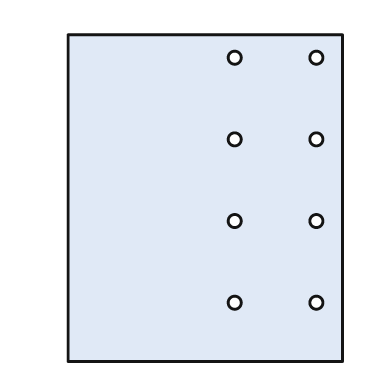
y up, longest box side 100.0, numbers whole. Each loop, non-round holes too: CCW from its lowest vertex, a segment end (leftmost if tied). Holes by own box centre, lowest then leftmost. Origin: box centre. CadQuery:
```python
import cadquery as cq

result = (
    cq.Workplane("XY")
    .moveTo(-42.0, -50.0)
    .lineTo(42.0, -50.0)
    .lineTo(42.0, 50.0)
    .lineTo(-42.0, 50.0)
    .close()
    .moveTo(9.0, -32.0)
    .circle(2.0)
    .moveTo(34.0, -32.0)
    .circle(2.0)
    .moveTo(9.0, -7.0)
    .circle(2.0)
    .moveTo(34.0, -7.0)
    .circle(2.0)
    .moveTo(9.0, 18.0)
    .circle(2.0)
    .moveTo(34.0, 18.0)
    .circle(2.0)
    .moveTo(9.0, 43.0)
    .circle(2.0)
    .moveTo(34.0, 43.0)
    .circle(2.0)
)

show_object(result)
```